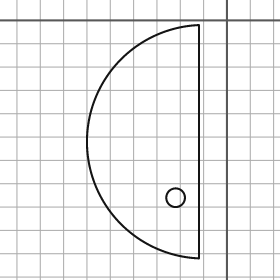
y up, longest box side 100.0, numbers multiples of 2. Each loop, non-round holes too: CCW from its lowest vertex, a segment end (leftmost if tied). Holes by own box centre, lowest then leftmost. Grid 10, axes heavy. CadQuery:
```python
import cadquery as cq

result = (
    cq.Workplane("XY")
    .moveTo(-12.0, -102.0)
    .lineTo(-12.0, -2.0)
    .threePointArc((-60.0, -52.0), (-12.0, -102.0))
    .close()
    .moveTo(-22.0, -76.0)
    .circle(4.0)
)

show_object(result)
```